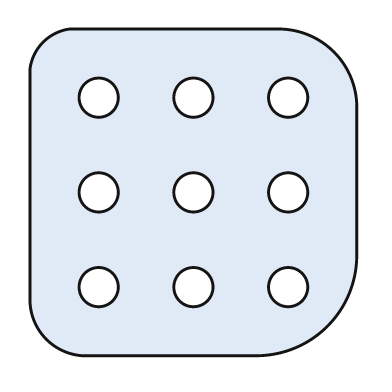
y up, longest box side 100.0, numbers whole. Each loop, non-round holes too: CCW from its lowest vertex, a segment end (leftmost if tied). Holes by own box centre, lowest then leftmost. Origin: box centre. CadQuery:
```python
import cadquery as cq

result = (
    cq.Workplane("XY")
    .moveTo(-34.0, -50.0)
    .lineTo(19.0, -50.0)
    .threePointArc((41.0, -41.0), (50.0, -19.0))
    .lineTo(50.0, 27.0)
    .threePointArc((43.0, 43.0), (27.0, 50.0))
    .lineTo(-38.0, 50.0)
    .threePointArc((-46.0, 46.0), (-50.0, 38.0))
    .lineTo(-50.0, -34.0)
    .threePointArc((-45.0, -45.0), (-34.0, -50.0))
    .close()
    .moveTo(-29.0, -29.0)
    .circle(6.0)
    .moveTo(0.0, -29.0)
    .circle(6.0)
    .moveTo(29.0, -29.0)
    .circle(6.0)
    .moveTo(-29.0, 0.0)
    .circle(6.0)
    .moveTo(0.0, 0.0)
    .circle(6.0)
    .moveTo(29.0, 0.0)
    .circle(6.0)
    .moveTo(-29.0, 29.0)
    .circle(6.0)
    .moveTo(0.0, 29.0)
    .circle(6.0)
    .moveTo(29.0, 29.0)
    .circle(6.0)
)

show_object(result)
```